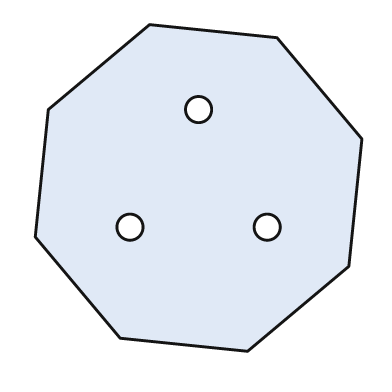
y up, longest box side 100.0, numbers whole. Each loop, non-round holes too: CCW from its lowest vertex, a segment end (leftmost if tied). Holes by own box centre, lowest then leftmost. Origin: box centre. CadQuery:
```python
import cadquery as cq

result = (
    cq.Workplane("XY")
    .moveTo(15.0, -50.0)
    .lineTo(46.0, -24.0)
    .lineTo(50.0, 15.0)
    .lineTo(24.0, 46.0)
    .lineTo(-15.0, 50.0)
    .lineTo(-46.0, 24.0)
    .lineTo(-50.0, -15.0)
    .lineTo(-24.0, -46.0)
    .close()
    .moveTo(-21.0, -12.0)
    .circle(4.0)
    .moveTo(21.0, -12.0)
    .circle(4.0)
    .moveTo(0.0, 24.0)
    .circle(4.0)
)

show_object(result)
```